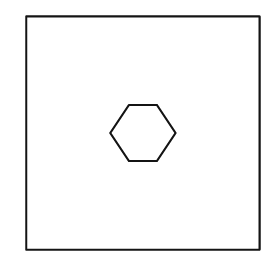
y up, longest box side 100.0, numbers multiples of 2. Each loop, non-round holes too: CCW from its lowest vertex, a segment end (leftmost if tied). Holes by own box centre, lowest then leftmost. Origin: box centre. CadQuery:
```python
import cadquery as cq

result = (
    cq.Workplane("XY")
    .moveTo(-50.0, -50.0)
    .lineTo(50.0, -50.0)
    .lineTo(50.0, 50.0)
    .lineTo(-50.0, 50.0)
    .close()
    .moveTo(-6.0, -12.0)
    .lineTo(6.0, -12.0)
    .lineTo(14.0, 0.0)
    .lineTo(6.0, 12.0)
    .lineTo(-6.0, 12.0)
    .lineTo(-14.0, 0.0)
    .close()
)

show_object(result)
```